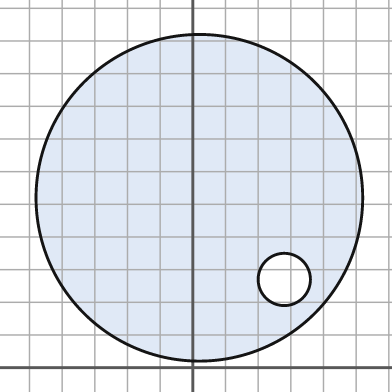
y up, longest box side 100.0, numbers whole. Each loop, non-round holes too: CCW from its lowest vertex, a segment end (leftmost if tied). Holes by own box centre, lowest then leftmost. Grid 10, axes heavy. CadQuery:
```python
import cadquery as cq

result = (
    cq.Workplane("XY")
    .moveTo(2.0, 52.0)
    .circle(50.0)
    .moveTo(28.0, 27.0)
    .circle(8.0)
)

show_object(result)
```